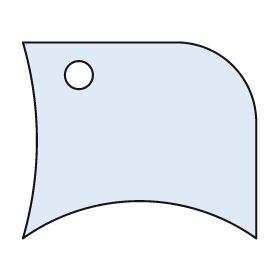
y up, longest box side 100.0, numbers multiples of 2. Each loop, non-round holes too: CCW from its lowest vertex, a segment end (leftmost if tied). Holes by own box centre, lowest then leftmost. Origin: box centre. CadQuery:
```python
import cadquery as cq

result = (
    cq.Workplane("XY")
    .moveTo(-50.0, -42.0)
    .threePointArc((0.0, -26.0), (50.0, -42.0))
    .lineTo(50.0, 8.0)
    .threePointArc((40.0, 32.0), (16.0, 42.0))
    .lineTo(-50.0, 42.0)
    .threePointArc((-44.0, 0.0), (-50.0, -42.0))
    .close()
    .moveTo(-26.0, 28.0)
    .circle(6.0)
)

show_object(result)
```